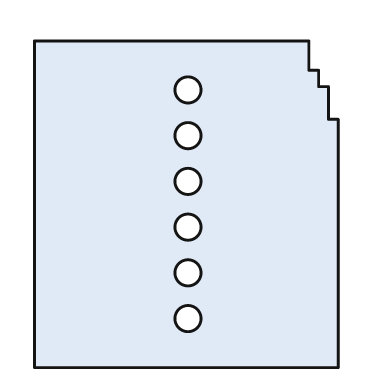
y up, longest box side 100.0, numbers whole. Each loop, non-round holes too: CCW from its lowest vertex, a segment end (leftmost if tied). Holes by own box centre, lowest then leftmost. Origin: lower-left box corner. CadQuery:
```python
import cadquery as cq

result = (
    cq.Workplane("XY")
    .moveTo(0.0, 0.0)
    .lineTo(93.0, 0.0)
    .lineTo(93.0, 76.0)
    .lineTo(90.0, 76.0)
    .lineTo(90.0, 86.0)
    .lineTo(87.0, 86.0)
    .lineTo(87.0, 91.0)
    .lineTo(84.0, 91.0)
    .lineTo(84.0, 100.0)
    .lineTo(0.0, 100.0)
    .close()
    .moveTo(47.0, 15.0)
    .circle(4.0)
    .moveTo(47.0, 29.0)
    .circle(4.0)
    .moveTo(47.0, 43.0)
    .circle(4.0)
    .moveTo(47.0, 57.0)
    .circle(4.0)
    .moveTo(47.0, 71.0)
    .circle(4.0)
    .moveTo(47.0, 85.0)
    .circle(4.0)
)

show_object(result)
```